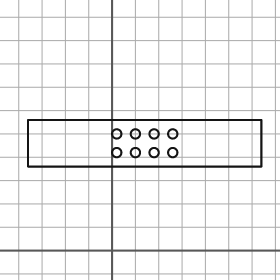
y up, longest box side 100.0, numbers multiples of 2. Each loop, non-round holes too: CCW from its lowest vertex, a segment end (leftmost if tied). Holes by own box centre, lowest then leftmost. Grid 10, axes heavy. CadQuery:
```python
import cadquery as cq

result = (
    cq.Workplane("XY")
    .moveTo(-36.0, 36.0)
    .lineTo(64.0, 36.0)
    .lineTo(64.0, 56.0)
    .lineTo(-36.0, 56.0)
    .close()
    .moveTo(2.0, 42.0)
    .circle(2.0)
    .moveTo(10.0, 42.0)
    .circle(2.0)
    .moveTo(18.0, 42.0)
    .circle(2.0)
    .moveTo(26.0, 42.0)
    .circle(2.0)
    .moveTo(2.0, 50.0)
    .circle(2.0)
    .moveTo(10.0, 50.0)
    .circle(2.0)
    .moveTo(18.0, 50.0)
    .circle(2.0)
    .moveTo(26.0, 50.0)
    .circle(2.0)
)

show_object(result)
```